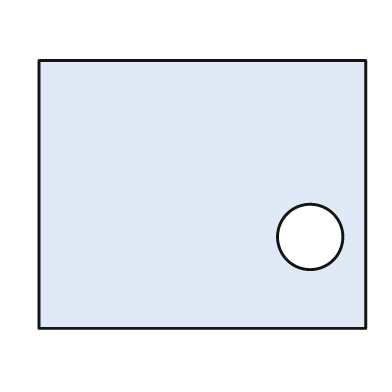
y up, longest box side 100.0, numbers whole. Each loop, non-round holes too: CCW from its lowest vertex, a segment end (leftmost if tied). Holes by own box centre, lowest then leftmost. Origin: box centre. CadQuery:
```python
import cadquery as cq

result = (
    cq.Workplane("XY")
    .moveTo(-50.0, -41.0)
    .lineTo(50.0, -41.0)
    .lineTo(50.0, 41.0)
    .lineTo(-50.0, 41.0)
    .close()
    .moveTo(33.0, -13.0)
    .circle(10.0)
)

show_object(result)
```